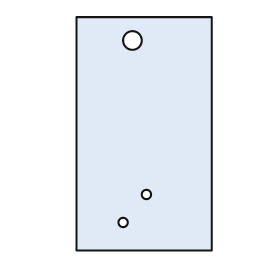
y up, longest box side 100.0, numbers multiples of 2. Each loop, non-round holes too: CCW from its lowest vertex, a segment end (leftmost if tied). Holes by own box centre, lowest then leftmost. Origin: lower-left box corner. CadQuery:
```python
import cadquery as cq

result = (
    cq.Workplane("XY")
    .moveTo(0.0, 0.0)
    .lineTo(58.0, 0.0)
    .lineTo(58.0, 100.0)
    .lineTo(0.0, 100.0)
    .close()
    .moveTo(20.0, 12.0)
    .circle(2.0)
    .moveTo(30.0, 24.0)
    .circle(2.0)
    .moveTo(24.0, 90.0)
    .circle(4.0)
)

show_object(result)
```